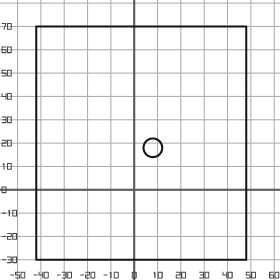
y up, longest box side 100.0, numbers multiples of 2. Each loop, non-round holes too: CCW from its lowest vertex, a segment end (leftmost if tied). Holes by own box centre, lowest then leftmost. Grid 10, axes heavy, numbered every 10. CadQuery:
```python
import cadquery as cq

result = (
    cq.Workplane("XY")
    .moveTo(-42.0, -30.0)
    .lineTo(48.0, -30.0)
    .lineTo(48.0, 70.0)
    .lineTo(-42.0, 70.0)
    .close()
    .moveTo(8.0, 18.0)
    .circle(4.0)
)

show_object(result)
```